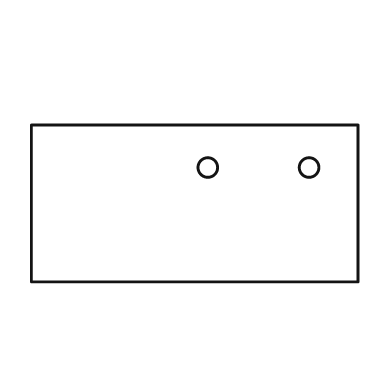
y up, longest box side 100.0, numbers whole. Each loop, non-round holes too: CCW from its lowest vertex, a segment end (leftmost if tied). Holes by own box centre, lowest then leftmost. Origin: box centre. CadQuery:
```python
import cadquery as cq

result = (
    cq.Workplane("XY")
    .moveTo(-50.0, -24.0)
    .lineTo(50.0, -24.0)
    .lineTo(50.0, 24.0)
    .lineTo(-50.0, 24.0)
    .close()
    .moveTo(4.0, 11.0)
    .circle(3.0)
    .moveTo(35.0, 11.0)
    .circle(3.0)
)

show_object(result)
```